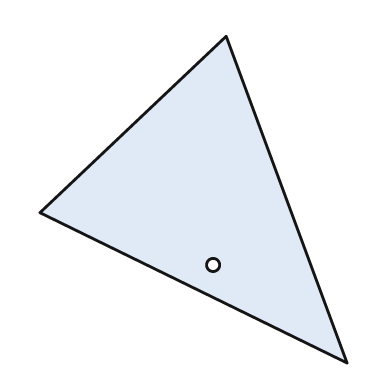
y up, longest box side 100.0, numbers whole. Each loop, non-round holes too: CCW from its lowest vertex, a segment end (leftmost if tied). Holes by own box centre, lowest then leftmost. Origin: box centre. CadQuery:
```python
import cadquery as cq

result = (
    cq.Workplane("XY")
    .moveTo(47.0, -50.0)
    .lineTo(10.0, 50.0)
    .lineTo(-47.0, -4.0)
    .close()
    .moveTo(6.0, -20.0)
    .circle(2.0)
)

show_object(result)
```